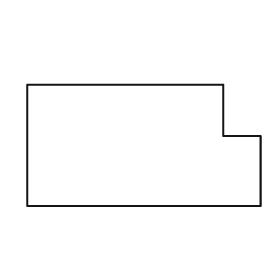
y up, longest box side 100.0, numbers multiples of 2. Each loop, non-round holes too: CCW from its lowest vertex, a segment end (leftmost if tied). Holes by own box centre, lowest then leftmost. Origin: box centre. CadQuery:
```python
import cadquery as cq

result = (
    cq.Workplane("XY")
    .moveTo(-50.0, -26.0)
    .lineTo(50.0, -26.0)
    .lineTo(50.0, 4.0)
    .lineTo(34.0, 4.0)
    .lineTo(34.0, 26.0)
    .lineTo(-50.0, 26.0)
    .close()
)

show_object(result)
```